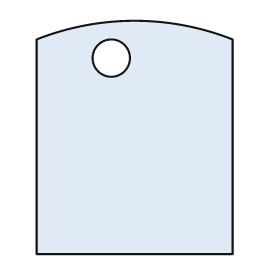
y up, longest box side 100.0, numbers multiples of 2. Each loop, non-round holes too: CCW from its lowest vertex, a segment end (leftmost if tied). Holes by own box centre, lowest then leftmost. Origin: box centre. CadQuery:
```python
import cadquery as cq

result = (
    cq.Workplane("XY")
    .moveTo(-42.0, -50.0)
    .lineTo(42.0, -50.0)
    .lineTo(42.0, 42.0)
    .threePointArc((0.0, 50.0), (-42.0, 42.0))
    .close()
    .moveTo(-10.0, 34.0)
    .circle(8.0)
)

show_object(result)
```